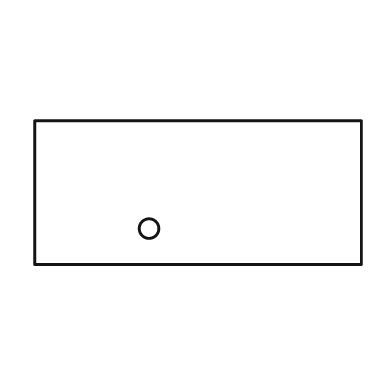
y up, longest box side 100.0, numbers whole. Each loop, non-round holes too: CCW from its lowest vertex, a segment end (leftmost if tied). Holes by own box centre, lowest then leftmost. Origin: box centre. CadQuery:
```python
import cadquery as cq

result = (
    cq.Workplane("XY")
    .moveTo(-50.0, -22.0)
    .lineTo(50.0, -22.0)
    .lineTo(50.0, 22.0)
    .lineTo(-50.0, 22.0)
    .close()
    .moveTo(-15.0, -11.0)
    .circle(3.0)
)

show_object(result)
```